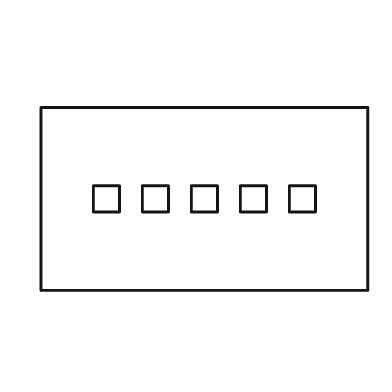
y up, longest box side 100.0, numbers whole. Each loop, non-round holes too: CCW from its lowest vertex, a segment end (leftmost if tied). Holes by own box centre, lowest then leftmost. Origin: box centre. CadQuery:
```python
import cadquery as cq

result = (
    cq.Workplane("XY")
    .moveTo(-50.0, -28.0)
    .lineTo(50.0, -28.0)
    .lineTo(50.0, 28.0)
    .lineTo(-50.0, 28.0)
    .close()
    .moveTo(-34.0, -4.0)
    .lineTo(-26.0, -4.0)
    .lineTo(-26.0, 4.0)
    .lineTo(-34.0, 4.0)
    .close()
    .moveTo(-19.0, -4.0)
    .lineTo(-11.0, -4.0)
    .lineTo(-11.0, 4.0)
    .lineTo(-19.0, 4.0)
    .close()
    .moveTo(-4.0, -4.0)
    .lineTo(4.0, -4.0)
    .lineTo(4.0, 4.0)
    .lineTo(-4.0, 4.0)
    .close()
    .moveTo(11.0, -4.0)
    .lineTo(19.0, -4.0)
    .lineTo(19.0, 4.0)
    .lineTo(11.0, 4.0)
    .close()
    .moveTo(26.0, -4.0)
    .lineTo(34.0, -4.0)
    .lineTo(34.0, 4.0)
    .lineTo(26.0, 4.0)
    .close()
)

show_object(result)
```